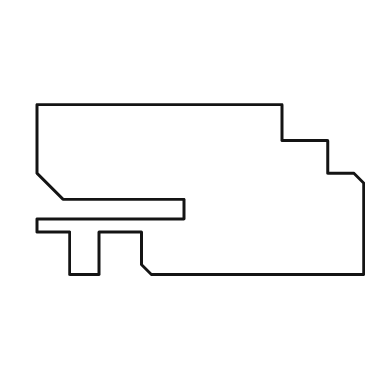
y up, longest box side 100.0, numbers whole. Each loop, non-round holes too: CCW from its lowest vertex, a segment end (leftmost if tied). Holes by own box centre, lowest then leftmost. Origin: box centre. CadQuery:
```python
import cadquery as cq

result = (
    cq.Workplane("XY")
    .moveTo(-40.0, -26.0)
    .lineTo(-31.0, -26.0)
    .lineTo(-31.0, -13.0)
    .lineTo(-18.0, -13.0)
    .lineTo(-18.0, -23.0)
    .lineTo(-15.0, -26.0)
    .lineTo(50.0, -26.0)
    .lineTo(50.0, 2.0)
    .lineTo(47.0, 5.0)
    .lineTo(39.0, 5.0)
    .lineTo(39.0, 15.0)
    .lineTo(25.0, 15.0)
    .lineTo(25.0, 26.0)
    .lineTo(-50.0, 26.0)
    .lineTo(-50.0, 5.0)
    .lineTo(-42.0, -3.0)
    .lineTo(-5.0, -3.0)
    .lineTo(-5.0, -9.0)
    .lineTo(-50.0, -9.0)
    .lineTo(-50.0, -13.0)
    .lineTo(-40.0, -13.0)
    .close()
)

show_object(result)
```